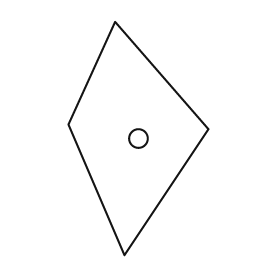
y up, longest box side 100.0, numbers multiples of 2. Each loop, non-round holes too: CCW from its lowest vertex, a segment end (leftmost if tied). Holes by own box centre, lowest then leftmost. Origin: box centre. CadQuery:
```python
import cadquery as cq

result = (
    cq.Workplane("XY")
    .moveTo(-6.0, -50.0)
    .lineTo(30.0, 4.0)
    .lineTo(-10.0, 50.0)
    .lineTo(-30.0, 6.0)
    .close()
    .moveTo(0.0, 0.0)
    .circle(4.0)
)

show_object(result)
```